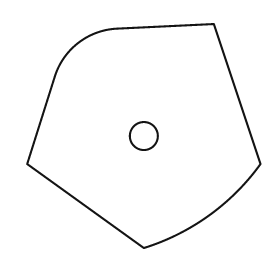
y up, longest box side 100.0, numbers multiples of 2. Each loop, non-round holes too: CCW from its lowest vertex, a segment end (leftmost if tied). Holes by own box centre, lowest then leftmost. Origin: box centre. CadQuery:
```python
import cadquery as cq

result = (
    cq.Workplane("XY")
    .moveTo(0.0, -48.0)
    .threePointArc((28.0, -34.0), (50.0, -12.0))
    .lineTo(30.0, 48.0)
    .lineTo(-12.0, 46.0)
    .threePointArc((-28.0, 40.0), (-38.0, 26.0))
    .lineTo(-50.0, -12.0)
    .close()
    .moveTo(0.0, 0.0)
    .circle(6.0)
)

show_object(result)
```